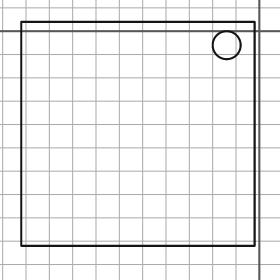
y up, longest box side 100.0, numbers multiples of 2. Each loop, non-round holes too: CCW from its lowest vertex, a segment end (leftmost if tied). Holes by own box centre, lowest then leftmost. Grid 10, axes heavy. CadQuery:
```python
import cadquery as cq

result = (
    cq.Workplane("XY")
    .moveTo(-102.0, -92.0)
    .lineTo(-2.0, -92.0)
    .lineTo(-2.0, 4.0)
    .lineTo(-102.0, 4.0)
    .close()
    .moveTo(-14.0, -6.0)
    .circle(6.0)
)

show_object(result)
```